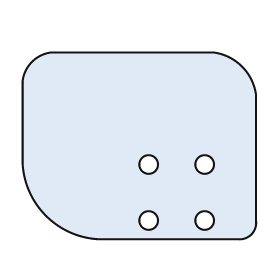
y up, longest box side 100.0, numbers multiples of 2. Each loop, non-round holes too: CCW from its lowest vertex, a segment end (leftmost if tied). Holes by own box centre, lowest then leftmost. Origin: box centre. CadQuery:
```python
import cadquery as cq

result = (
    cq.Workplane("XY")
    .moveTo(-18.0, -40.0)
    .lineTo(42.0, -40.0)
    .threePointArc((48.0, -38.0), (50.0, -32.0))
    .lineTo(50.0, 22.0)
    .threePointArc((44.0, 34.0), (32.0, 40.0))
    .lineTo(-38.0, 40.0)
    .threePointArc((-46.0, 36.0), (-50.0, 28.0))
    .lineTo(-50.0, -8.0)
    .threePointArc((-40.0, -30.0), (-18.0, -40.0))
    .close()
    .moveTo(4.0, -32.0)
    .circle(4.0)
    .moveTo(28.0, -32.0)
    .circle(4.0)
    .moveTo(4.0, -8.0)
    .circle(4.0)
    .moveTo(28.0, -8.0)
    .circle(4.0)
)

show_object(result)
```